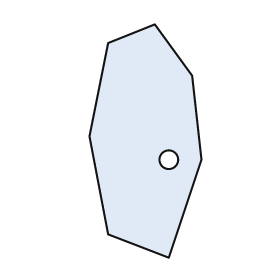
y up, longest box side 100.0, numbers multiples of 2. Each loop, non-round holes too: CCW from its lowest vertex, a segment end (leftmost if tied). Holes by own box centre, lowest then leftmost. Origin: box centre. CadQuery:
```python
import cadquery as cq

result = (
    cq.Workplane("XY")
    .moveTo(10.0, -50.0)
    .lineTo(24.0, -8.0)
    .lineTo(20.0, 28.0)
    .lineTo(4.0, 50.0)
    .lineTo(-16.0, 42.0)
    .lineTo(-24.0, 2.0)
    .lineTo(-16.0, -40.0)
    .close()
    .moveTo(10.0, -8.0)
    .circle(4.0)
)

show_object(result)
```